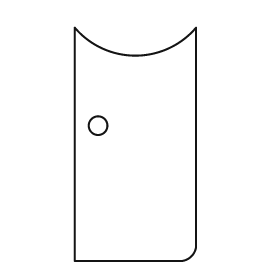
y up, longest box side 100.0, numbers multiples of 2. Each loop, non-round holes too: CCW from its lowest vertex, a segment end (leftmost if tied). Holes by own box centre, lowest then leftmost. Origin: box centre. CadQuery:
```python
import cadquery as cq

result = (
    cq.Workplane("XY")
    .moveTo(-26.0, -50.0)
    .lineTo(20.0, -50.0)
    .threePointArc((24.0, -48.0), (26.0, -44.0))
    .lineTo(26.0, 50.0)
    .threePointArc((0.0, 38.0), (-26.0, 50.0))
    .close()
    .moveTo(-16.0, 8.0)
    .circle(4.0)
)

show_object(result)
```